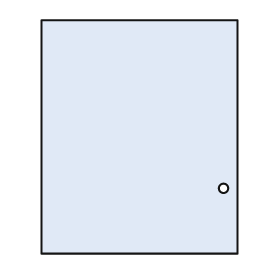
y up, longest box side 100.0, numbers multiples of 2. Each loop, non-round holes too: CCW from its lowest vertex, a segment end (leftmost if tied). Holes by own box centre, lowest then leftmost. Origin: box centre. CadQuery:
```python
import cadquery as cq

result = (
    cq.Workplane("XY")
    .moveTo(-42.0, -50.0)
    .lineTo(42.0, -50.0)
    .lineTo(42.0, 50.0)
    .lineTo(-42.0, 50.0)
    .close()
    .moveTo(36.0, -22.0)
    .circle(2.0)
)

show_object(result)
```